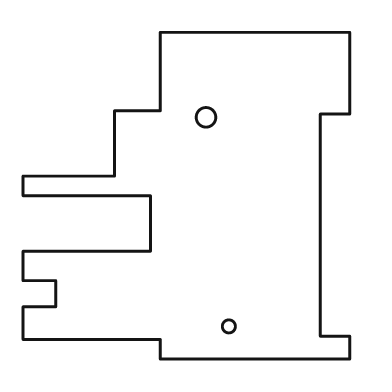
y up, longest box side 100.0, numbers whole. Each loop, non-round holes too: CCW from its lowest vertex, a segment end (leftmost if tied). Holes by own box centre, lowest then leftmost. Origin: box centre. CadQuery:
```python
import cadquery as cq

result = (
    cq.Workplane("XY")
    .moveTo(-8.0, -50.0)
    .lineTo(50.0, -50.0)
    .lineTo(50.0, -43.0)
    .lineTo(41.0, -43.0)
    .lineTo(41.0, 25.0)
    .lineTo(50.0, 25.0)
    .lineTo(50.0, 50.0)
    .lineTo(-8.0, 50.0)
    .lineTo(-8.0, 26.0)
    .lineTo(-22.0, 26.0)
    .lineTo(-22.0, 6.0)
    .lineTo(-50.0, 6.0)
    .lineTo(-50.0, 0.0)
    .lineTo(-11.0, 0.0)
    .lineTo(-11.0, -17.0)
    .lineTo(-50.0, -17.0)
    .lineTo(-50.0, -26.0)
    .lineTo(-40.0, -26.0)
    .lineTo(-40.0, -34.0)
    .lineTo(-50.0, -34.0)
    .lineTo(-50.0, -44.0)
    .lineTo(-8.0, -44.0)
    .close()
    .moveTo(13.0, -40.0)
    .circle(2.0)
    .moveTo(6.0, 24.0)
    .circle(3.0)
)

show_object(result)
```